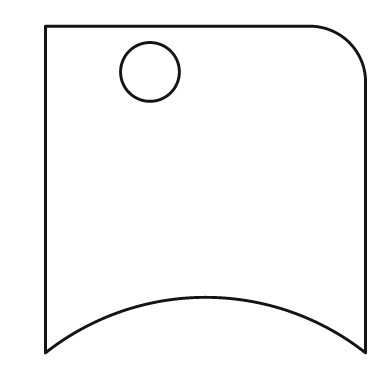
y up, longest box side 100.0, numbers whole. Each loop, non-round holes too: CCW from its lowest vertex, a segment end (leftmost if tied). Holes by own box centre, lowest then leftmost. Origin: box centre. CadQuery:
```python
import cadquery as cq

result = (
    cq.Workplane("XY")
    .moveTo(-49.0, -50.0)
    .threePointArc((0.0, -33.0), (49.0, -50.0))
    .lineTo(49.0, 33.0)
    .threePointArc((44.0, 45.0), (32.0, 50.0))
    .lineTo(-49.0, 50.0)
    .close()
    .moveTo(-17.0, 36.0)
    .circle(9.0)
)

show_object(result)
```